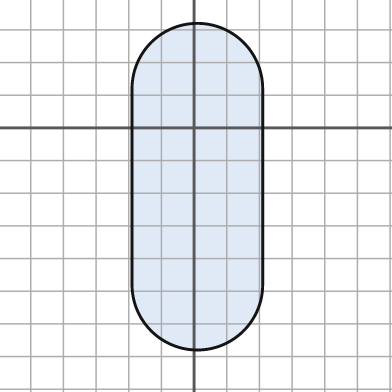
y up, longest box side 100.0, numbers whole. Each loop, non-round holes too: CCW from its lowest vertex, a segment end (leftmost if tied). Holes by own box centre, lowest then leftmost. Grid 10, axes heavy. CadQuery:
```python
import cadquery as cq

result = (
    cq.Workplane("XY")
    .moveTo(-19.0, -48.0)
    .threePointArc((1.0, -68.0), (21.0, -48.0))
    .lineTo(21.0, 12.0)
    .threePointArc((1.0, 32.0), (-19.0, 12.0))
    .close()
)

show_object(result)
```